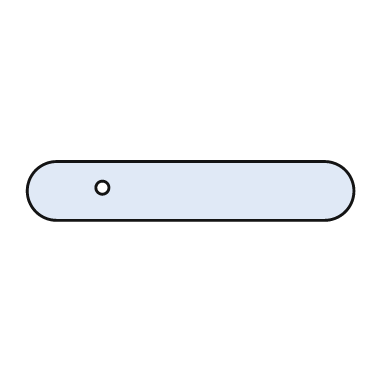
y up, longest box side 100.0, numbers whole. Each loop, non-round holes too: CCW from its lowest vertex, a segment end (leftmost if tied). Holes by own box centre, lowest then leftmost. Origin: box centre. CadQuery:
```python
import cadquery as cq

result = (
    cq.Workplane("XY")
    .moveTo(-41.0, -9.0)
    .lineTo(41.0, -9.0)
    .threePointArc((50.0, 0.0), (41.0, 9.0))
    .lineTo(-41.0, 9.0)
    .threePointArc((-50.0, 0.0), (-41.0, -9.0))
    .close()
    .moveTo(-27.0, 1.0)
    .circle(2.0)
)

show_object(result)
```